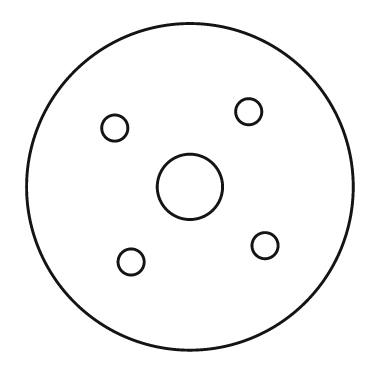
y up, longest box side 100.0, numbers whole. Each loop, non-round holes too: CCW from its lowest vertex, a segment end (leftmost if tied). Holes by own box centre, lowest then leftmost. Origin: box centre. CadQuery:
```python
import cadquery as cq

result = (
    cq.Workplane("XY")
    .moveTo(0.0, 0.0)
    .circle(50.0)
    .moveTo(-18.0, -23.0)
    .circle(4.0)
    .moveTo(23.0, -18.0)
    .circle(4.0)
    .moveTo(0.0, 0.0)
    .circle(10.0)
    .moveTo(-23.0, 18.0)
    .circle(4.0)
    .moveTo(18.0, 23.0)
    .circle(4.0)
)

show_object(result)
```